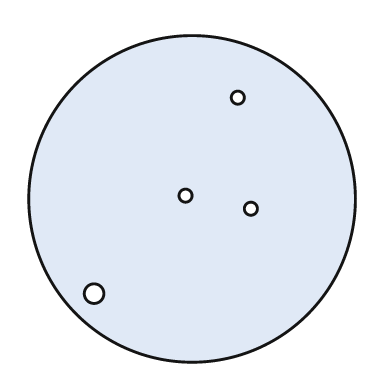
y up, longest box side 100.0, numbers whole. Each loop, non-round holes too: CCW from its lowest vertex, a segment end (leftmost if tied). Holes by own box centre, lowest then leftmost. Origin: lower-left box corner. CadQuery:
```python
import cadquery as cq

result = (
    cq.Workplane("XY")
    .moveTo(50.0, 50.0)
    .circle(50.0)
    .moveTo(20.0, 21.0)
    .circle(3.0)
    .moveTo(68.0, 47.0)
    .circle(2.0)
    .moveTo(48.0, 51.0)
    .circle(2.0)
    .moveTo(64.0, 81.0)
    .circle(2.0)
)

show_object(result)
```